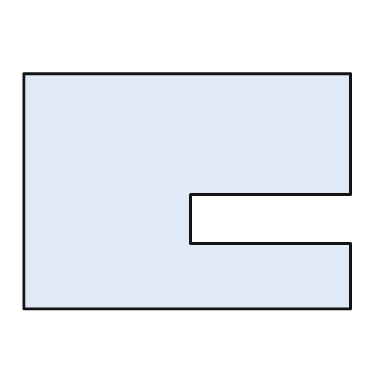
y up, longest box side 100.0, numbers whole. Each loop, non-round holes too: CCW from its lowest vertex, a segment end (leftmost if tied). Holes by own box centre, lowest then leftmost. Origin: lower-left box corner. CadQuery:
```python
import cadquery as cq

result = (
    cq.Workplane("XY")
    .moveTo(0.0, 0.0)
    .lineTo(100.0, 0.0)
    .lineTo(100.0, 20.0)
    .lineTo(51.0, 20.0)
    .lineTo(51.0, 35.0)
    .lineTo(100.0, 35.0)
    .lineTo(100.0, 72.0)
    .lineTo(0.0, 72.0)
    .close()
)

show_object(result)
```